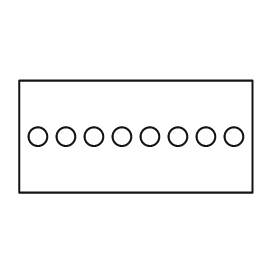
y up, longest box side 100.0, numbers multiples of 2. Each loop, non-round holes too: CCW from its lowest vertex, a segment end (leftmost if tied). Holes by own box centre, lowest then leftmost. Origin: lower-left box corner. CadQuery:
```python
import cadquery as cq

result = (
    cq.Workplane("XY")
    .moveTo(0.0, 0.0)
    .lineTo(100.0, 0.0)
    .lineTo(100.0, 48.0)
    .lineTo(0.0, 48.0)
    .close()
    .moveTo(8.0, 24.0)
    .circle(4.0)
    .moveTo(20.0, 24.0)
    .circle(4.0)
    .moveTo(32.0, 24.0)
    .circle(4.0)
    .moveTo(44.0, 24.0)
    .circle(4.0)
    .moveTo(56.0, 24.0)
    .circle(4.0)
    .moveTo(68.0, 24.0)
    .circle(4.0)
    .moveTo(80.0, 24.0)
    .circle(4.0)
    .moveTo(92.0, 24.0)
    .circle(4.0)
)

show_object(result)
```